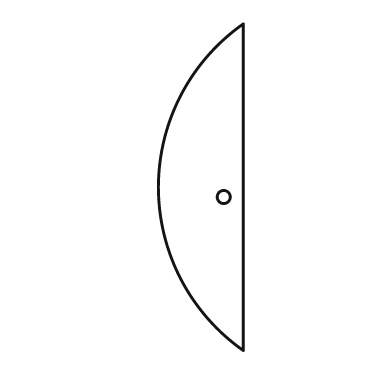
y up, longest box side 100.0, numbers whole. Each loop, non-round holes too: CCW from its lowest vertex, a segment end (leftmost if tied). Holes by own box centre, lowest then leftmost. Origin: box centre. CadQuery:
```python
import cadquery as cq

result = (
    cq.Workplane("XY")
    .moveTo(13.0, -50.0)
    .lineTo(13.0, 50.0)
    .threePointArc((-13.0, 0.0), (13.0, -50.0))
    .close()
    .moveTo(7.0, -3.0)
    .circle(2.0)
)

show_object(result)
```